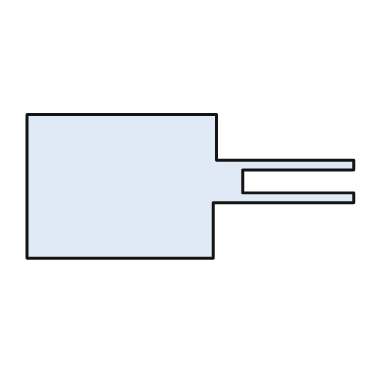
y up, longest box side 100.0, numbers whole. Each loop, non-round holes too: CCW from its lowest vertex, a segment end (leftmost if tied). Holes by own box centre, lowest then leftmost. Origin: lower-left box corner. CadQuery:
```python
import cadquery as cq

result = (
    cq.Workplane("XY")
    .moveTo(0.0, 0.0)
    .lineTo(57.0, 0.0)
    .lineTo(57.0, 17.0)
    .lineTo(100.0, 17.0)
    .lineTo(100.0, 20.0)
    .lineTo(66.0, 20.0)
    .lineTo(66.0, 27.0)
    .lineTo(100.0, 27.0)
    .lineTo(100.0, 30.0)
    .lineTo(58.0, 30.0)
    .lineTo(58.0, 44.0)
    .lineTo(0.0, 44.0)
    .close()
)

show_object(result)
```